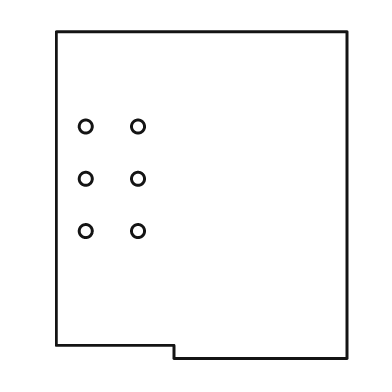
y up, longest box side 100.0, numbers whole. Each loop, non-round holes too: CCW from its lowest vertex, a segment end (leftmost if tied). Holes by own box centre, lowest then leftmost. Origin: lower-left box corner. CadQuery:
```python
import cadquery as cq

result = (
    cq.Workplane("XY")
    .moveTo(36.0, 0.0)
    .lineTo(89.0, 0.0)
    .lineTo(89.0, 100.0)
    .lineTo(0.0, 100.0)
    .lineTo(0.0, 4.0)
    .lineTo(36.0, 4.0)
    .close()
    .moveTo(9.0, 39.0)
    .circle(2.0)
    .moveTo(25.0, 39.0)
    .circle(2.0)
    .moveTo(9.0, 55.0)
    .circle(2.0)
    .moveTo(25.0, 55.0)
    .circle(2.0)
    .moveTo(9.0, 71.0)
    .circle(2.0)
    .moveTo(25.0, 71.0)
    .circle(2.0)
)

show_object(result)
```